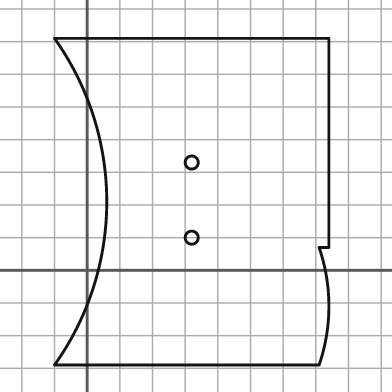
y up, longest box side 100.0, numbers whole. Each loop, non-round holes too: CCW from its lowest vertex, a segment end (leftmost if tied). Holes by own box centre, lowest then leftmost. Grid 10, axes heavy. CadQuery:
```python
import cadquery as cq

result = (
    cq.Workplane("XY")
    .moveTo(-10.0, -29.0)
    .lineTo(71.0, -29.0)
    .threePointArc((74.0, -11.0), (71.0, 7.0))
    .lineTo(74.0, 7.0)
    .lineTo(74.0, 71.0)
    .lineTo(-10.0, 71.0)
    .threePointArc((6.0, 21.0), (-10.0, -29.0))
    .close()
    .moveTo(32.0, 10.0)
    .circle(2.0)
    .moveTo(32.0, 33.0)
    .circle(2.0)
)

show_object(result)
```